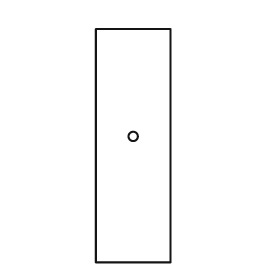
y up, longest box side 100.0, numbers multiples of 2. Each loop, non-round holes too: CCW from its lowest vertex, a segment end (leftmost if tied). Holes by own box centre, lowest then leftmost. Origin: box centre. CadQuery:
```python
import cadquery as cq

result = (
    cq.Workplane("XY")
    .moveTo(-16.0, -50.0)
    .lineTo(16.0, -50.0)
    .lineTo(16.0, 50.0)
    .lineTo(-16.0, 50.0)
    .close()
    .moveTo(0.0, 4.0)
    .circle(2.0)
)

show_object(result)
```